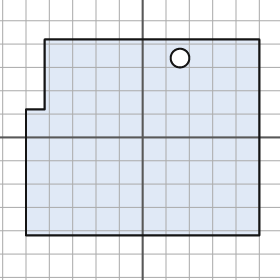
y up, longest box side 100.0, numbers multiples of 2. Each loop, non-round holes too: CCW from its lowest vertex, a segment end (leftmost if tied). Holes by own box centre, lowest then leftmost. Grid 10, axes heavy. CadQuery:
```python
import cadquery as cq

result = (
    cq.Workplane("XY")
    .moveTo(-50.0, -42.0)
    .lineTo(50.0, -42.0)
    .lineTo(50.0, 42.0)
    .lineTo(-42.0, 42.0)
    .lineTo(-42.0, 12.0)
    .lineTo(-50.0, 12.0)
    .close()
    .moveTo(16.0, 34.0)
    .circle(4.0)
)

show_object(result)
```